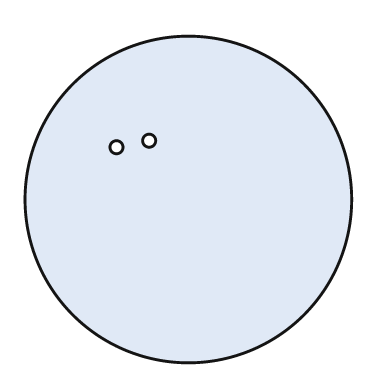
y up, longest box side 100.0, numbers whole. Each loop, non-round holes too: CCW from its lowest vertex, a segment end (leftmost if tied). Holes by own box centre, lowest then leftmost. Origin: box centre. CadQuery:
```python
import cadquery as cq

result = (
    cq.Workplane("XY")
    .moveTo(0.0, 0.0)
    .circle(50.0)
    .moveTo(-22.0, 16.0)
    .circle(2.0)
    .moveTo(-12.0, 18.0)
    .circle(2.0)
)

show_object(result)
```